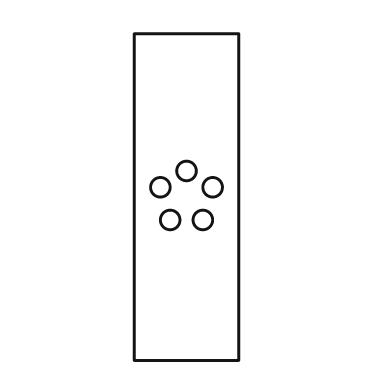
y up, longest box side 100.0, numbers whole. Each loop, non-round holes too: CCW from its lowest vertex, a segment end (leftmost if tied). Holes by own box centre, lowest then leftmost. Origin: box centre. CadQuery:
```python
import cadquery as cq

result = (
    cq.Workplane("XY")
    .moveTo(-16.0, -50.0)
    .lineTo(16.0, -50.0)
    .lineTo(16.0, 50.0)
    .lineTo(-16.0, 50.0)
    .close()
    .moveTo(-5.0, -7.0)
    .circle(3.0)
    .moveTo(5.0, -7.0)
    .circle(3.0)
    .moveTo(-8.0, 3.0)
    .circle(3.0)
    .moveTo(8.0, 3.0)
    .circle(3.0)
    .moveTo(0.0, 8.0)
    .circle(3.0)
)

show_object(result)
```